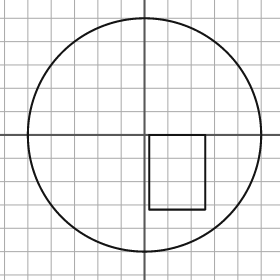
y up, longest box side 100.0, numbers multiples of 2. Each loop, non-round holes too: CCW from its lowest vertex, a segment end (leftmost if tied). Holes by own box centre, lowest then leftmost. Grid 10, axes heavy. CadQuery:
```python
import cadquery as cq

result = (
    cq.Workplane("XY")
    .moveTo(0.0, 0.0)
    .circle(50.0)
    .moveTo(2.0, -32.0)
    .lineTo(26.0, -32.0)
    .lineTo(26.0, 0.0)
    .lineTo(2.0, 0.0)
    .close()
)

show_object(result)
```